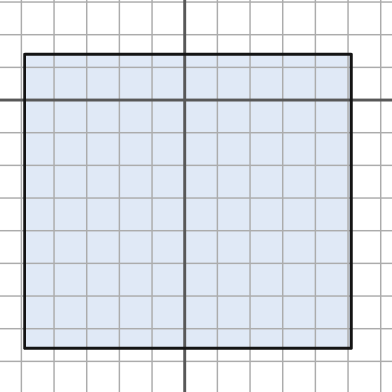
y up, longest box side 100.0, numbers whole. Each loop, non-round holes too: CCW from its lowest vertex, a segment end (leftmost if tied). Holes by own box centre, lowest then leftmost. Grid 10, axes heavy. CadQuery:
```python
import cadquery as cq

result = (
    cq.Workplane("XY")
    .moveTo(-49.0, -76.0)
    .lineTo(51.0, -76.0)
    .lineTo(51.0, 14.0)
    .lineTo(-49.0, 14.0)
    .close()
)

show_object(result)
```